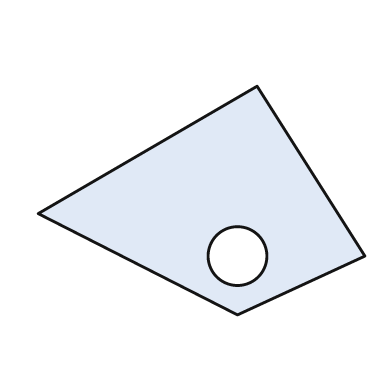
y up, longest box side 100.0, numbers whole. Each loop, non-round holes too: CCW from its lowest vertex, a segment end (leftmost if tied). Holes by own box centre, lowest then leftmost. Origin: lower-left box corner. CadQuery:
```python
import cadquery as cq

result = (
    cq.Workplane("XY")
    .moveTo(61.0, 0.0)
    .lineTo(100.0, 18.0)
    .lineTo(67.0, 70.0)
    .lineTo(0.0, 31.0)
    .close()
    .moveTo(61.0, 18.0)
    .circle(9.0)
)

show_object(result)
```